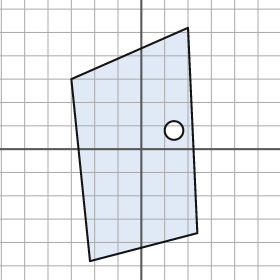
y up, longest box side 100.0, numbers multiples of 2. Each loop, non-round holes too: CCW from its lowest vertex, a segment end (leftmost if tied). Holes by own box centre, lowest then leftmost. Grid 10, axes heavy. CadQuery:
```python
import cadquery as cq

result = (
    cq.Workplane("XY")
    .moveTo(-22.0, -48.0)
    .lineTo(24.0, -36.0)
    .lineTo(20.0, 52.0)
    .lineTo(-30.0, 30.0)
    .close()
    .moveTo(14.0, 8.0)
    .circle(4.0)
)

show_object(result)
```